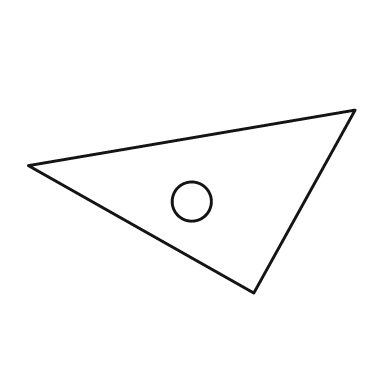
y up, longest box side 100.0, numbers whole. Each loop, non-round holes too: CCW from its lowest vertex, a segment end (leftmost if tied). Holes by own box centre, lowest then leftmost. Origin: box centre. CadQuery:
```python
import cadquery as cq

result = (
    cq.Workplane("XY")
    .moveTo(19.0, -28.0)
    .lineTo(50.0, 28.0)
    .lineTo(-50.0, 11.0)
    .close()
    .moveTo(0.0, 0.0)
    .circle(6.0)
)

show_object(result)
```